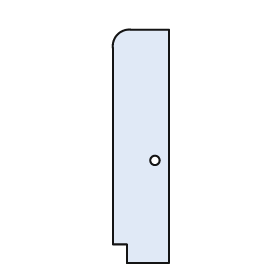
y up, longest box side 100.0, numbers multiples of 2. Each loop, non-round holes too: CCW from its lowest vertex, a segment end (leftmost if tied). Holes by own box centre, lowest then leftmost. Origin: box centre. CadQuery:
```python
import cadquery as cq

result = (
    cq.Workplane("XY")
    .moveTo(-6.0, -50.0)
    .lineTo(12.0, -50.0)
    .lineTo(12.0, 50.0)
    .lineTo(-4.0, 50.0)
    .threePointArc((-10.0, 48.0), (-12.0, 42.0))
    .lineTo(-12.0, -42.0)
    .lineTo(-6.0, -42.0)
    .close()
    .moveTo(6.0, -6.0)
    .circle(2.0)
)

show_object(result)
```